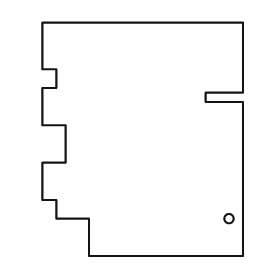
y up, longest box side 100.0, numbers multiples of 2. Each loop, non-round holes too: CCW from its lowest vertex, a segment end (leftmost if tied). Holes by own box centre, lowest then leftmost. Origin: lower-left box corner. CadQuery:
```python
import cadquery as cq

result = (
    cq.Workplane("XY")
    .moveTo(20.0, 0.0)
    .lineTo(86.0, 0.0)
    .lineTo(86.0, 66.0)
    .lineTo(70.0, 66.0)
    .lineTo(70.0, 70.0)
    .lineTo(86.0, 70.0)
    .lineTo(86.0, 100.0)
    .lineTo(0.0, 100.0)
    .lineTo(0.0, 80.0)
    .lineTo(6.0, 80.0)
    .lineTo(6.0, 72.0)
    .lineTo(0.0, 72.0)
    .lineTo(0.0, 56.0)
    .lineTo(10.0, 56.0)
    .lineTo(10.0, 40.0)
    .lineTo(0.0, 40.0)
    .lineTo(0.0, 24.0)
    .lineTo(6.0, 24.0)
    .lineTo(6.0, 16.0)
    .lineTo(20.0, 16.0)
    .close()
    .moveTo(80.0, 16.0)
    .circle(2.0)
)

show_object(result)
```